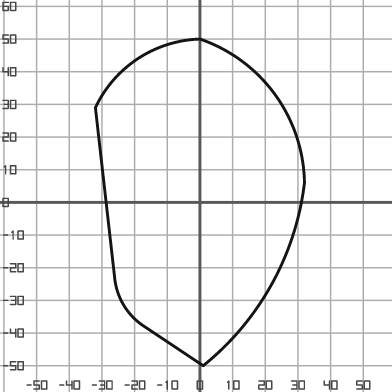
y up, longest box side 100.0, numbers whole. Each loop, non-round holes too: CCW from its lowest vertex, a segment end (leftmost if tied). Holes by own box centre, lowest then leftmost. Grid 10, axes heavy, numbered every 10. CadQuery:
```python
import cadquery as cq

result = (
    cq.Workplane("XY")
    .moveTo(1.0, -50.0)
    .threePointArc((22.0, -25.0), (32.0, 6.0))
    .threePointArc((23.0, 33.0), (0.0, 50.0))
    .threePointArc((-19.0, 44.0), (-32.0, 29.0))
    .lineTo(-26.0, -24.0)
    .threePointArc((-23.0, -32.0), (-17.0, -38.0))
    .close()
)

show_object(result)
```